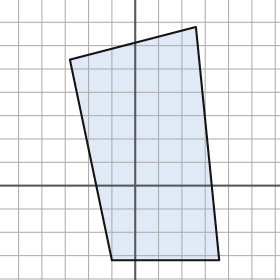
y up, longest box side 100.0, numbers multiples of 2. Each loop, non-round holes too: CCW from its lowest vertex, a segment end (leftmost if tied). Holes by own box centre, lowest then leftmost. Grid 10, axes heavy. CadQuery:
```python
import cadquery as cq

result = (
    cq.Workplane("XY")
    .moveTo(-10.0, -32.0)
    .lineTo(36.0, -32.0)
    .lineTo(26.0, 68.0)
    .lineTo(-28.0, 54.0)
    .close()
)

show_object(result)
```